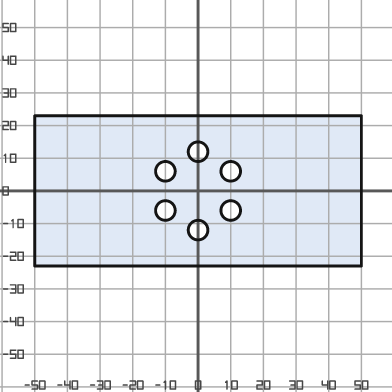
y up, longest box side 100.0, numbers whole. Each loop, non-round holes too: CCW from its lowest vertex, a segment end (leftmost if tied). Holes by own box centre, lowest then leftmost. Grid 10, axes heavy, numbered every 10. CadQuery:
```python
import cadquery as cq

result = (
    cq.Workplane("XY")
    .moveTo(-50.0, -23.0)
    .lineTo(50.0, -23.0)
    .lineTo(50.0, 23.0)
    .lineTo(-50.0, 23.0)
    .close()
    .moveTo(0.0, -12.0)
    .circle(3.0)
    .moveTo(-10.0, -6.0)
    .circle(3.0)
    .moveTo(10.0, -6.0)
    .circle(3.0)
    .moveTo(-10.0, 6.0)
    .circle(3.0)
    .moveTo(10.0, 6.0)
    .circle(3.0)
    .moveTo(0.0, 12.0)
    .circle(3.0)
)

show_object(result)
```